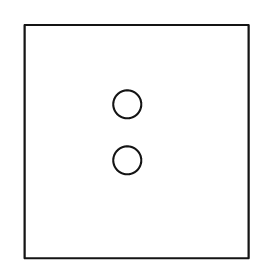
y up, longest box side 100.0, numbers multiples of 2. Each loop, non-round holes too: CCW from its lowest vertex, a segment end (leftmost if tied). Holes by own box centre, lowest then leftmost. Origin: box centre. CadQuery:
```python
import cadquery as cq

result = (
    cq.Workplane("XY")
    .moveTo(-48.0, -50.0)
    .lineTo(48.0, -50.0)
    .lineTo(48.0, 50.0)
    .lineTo(-48.0, 50.0)
    .close()
    .moveTo(-4.0, -8.0)
    .circle(6.0)
    .moveTo(-4.0, 16.0)
    .circle(6.0)
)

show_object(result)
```